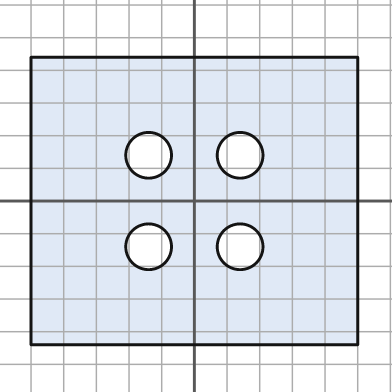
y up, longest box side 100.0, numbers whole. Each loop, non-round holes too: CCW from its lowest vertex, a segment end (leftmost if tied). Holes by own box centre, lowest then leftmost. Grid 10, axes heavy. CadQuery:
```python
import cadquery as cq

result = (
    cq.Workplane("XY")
    .moveTo(-50.0, -44.0)
    .lineTo(50.0, -44.0)
    .lineTo(50.0, 44.0)
    .lineTo(-50.0, 44.0)
    .close()
    .moveTo(-14.0, -14.0)
    .circle(7.0)
    .moveTo(14.0, -14.0)
    .circle(7.0)
    .moveTo(-14.0, 14.0)
    .circle(7.0)
    .moveTo(14.0, 14.0)
    .circle(7.0)
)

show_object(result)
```